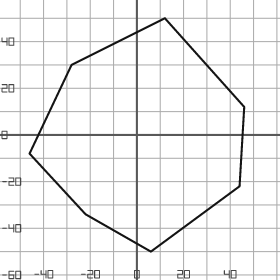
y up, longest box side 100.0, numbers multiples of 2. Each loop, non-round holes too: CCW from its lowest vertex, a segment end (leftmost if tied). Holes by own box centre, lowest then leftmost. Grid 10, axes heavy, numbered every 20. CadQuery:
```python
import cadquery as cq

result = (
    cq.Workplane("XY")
    .moveTo(6.0, -50.0)
    .lineTo(44.0, -22.0)
    .lineTo(46.0, 12.0)
    .lineTo(12.0, 50.0)
    .lineTo(-28.0, 30.0)
    .lineTo(-46.0, -8.0)
    .lineTo(-22.0, -34.0)
    .close()
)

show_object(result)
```